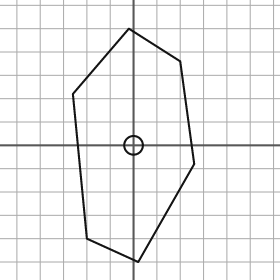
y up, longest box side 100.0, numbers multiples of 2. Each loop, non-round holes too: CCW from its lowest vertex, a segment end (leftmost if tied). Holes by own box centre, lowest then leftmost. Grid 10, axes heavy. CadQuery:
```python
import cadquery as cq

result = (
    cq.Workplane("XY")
    .moveTo(2.0, -50.0)
    .lineTo(26.0, -8.0)
    .lineTo(20.0, 36.0)
    .lineTo(-2.0, 50.0)
    .lineTo(-26.0, 22.0)
    .lineTo(-20.0, -40.0)
    .close()
    .moveTo(0.0, 0.0)
    .circle(4.0)
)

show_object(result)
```